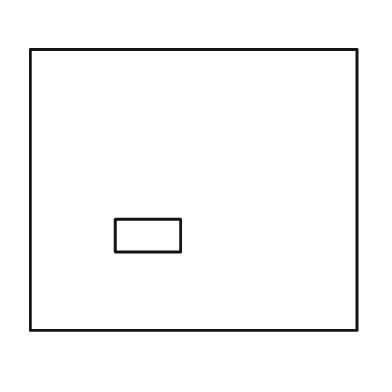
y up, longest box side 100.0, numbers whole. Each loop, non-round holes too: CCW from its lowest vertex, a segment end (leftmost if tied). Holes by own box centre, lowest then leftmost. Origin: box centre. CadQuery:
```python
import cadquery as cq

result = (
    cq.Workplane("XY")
    .moveTo(-50.0, -43.0)
    .lineTo(50.0, -43.0)
    .lineTo(50.0, 43.0)
    .lineTo(-50.0, 43.0)
    .close()
    .moveTo(-24.0, -19.0)
    .lineTo(-4.0, -19.0)
    .lineTo(-4.0, -9.0)
    .lineTo(-24.0, -9.0)
    .close()
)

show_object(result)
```